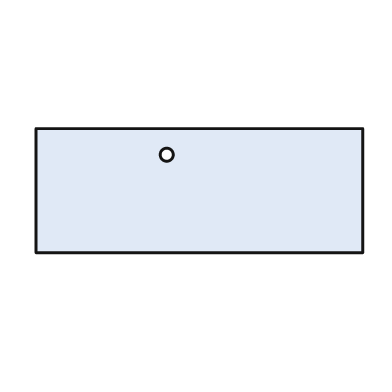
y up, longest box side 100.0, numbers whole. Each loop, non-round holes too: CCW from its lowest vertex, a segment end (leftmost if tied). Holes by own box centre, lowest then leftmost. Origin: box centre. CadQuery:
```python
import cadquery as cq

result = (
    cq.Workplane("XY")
    .moveTo(-50.0, -19.0)
    .lineTo(50.0, -19.0)
    .lineTo(50.0, 19.0)
    .lineTo(-50.0, 19.0)
    .close()
    .moveTo(-10.0, 11.0)
    .circle(2.0)
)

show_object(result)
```